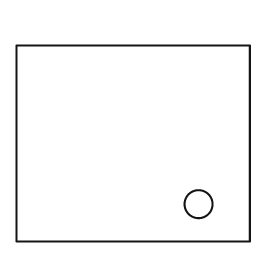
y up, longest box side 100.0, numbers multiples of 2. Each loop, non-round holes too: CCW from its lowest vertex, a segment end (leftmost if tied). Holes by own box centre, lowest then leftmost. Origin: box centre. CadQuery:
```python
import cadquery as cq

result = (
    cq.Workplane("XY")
    .moveTo(-50.0, -42.0)
    .lineTo(50.0, -42.0)
    .lineTo(50.0, 42.0)
    .lineTo(-50.0, 42.0)
    .close()
    .moveTo(28.0, -26.0)
    .circle(6.0)
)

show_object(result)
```